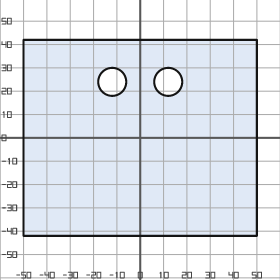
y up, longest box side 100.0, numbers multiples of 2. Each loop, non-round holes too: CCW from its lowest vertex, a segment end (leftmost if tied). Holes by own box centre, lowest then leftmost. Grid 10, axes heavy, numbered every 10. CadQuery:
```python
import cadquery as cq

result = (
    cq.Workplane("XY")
    .moveTo(-50.0, -42.0)
    .lineTo(50.0, -42.0)
    .lineTo(50.0, 42.0)
    .lineTo(-50.0, 42.0)
    .close()
    .moveTo(-12.0, 24.0)
    .circle(6.0)
    .moveTo(12.0, 24.0)
    .circle(6.0)
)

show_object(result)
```